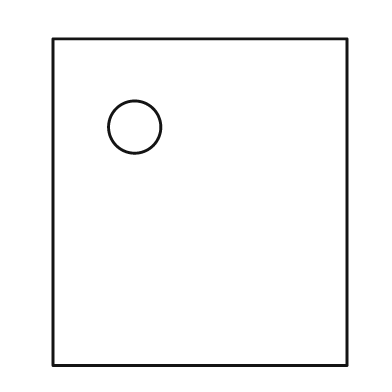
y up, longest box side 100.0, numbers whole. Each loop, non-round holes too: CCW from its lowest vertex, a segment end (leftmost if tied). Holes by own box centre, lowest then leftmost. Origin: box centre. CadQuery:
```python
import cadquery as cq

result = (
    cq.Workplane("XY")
    .moveTo(-45.0, -50.0)
    .lineTo(45.0, -50.0)
    .lineTo(45.0, 50.0)
    .lineTo(-45.0, 50.0)
    .close()
    .moveTo(-20.0, 23.0)
    .circle(8.0)
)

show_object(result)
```